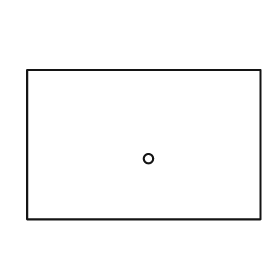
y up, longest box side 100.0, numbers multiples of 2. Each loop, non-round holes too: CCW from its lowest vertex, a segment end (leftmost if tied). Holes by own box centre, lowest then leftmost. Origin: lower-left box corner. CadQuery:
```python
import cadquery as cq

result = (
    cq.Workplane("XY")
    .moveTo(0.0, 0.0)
    .lineTo(100.0, 0.0)
    .lineTo(100.0, 64.0)
    .lineTo(0.0, 64.0)
    .close()
    .moveTo(52.0, 26.0)
    .circle(2.0)
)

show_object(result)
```